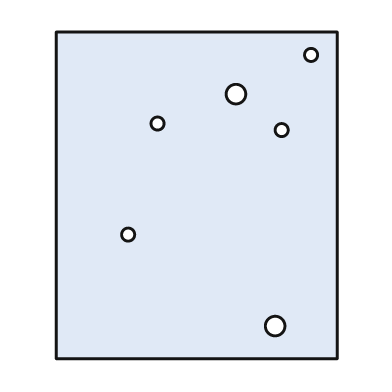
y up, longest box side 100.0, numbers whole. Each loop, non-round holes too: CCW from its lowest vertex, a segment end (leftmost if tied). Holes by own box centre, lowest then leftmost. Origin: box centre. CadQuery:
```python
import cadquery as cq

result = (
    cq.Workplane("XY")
    .moveTo(-43.0, -50.0)
    .lineTo(43.0, -50.0)
    .lineTo(43.0, 50.0)
    .lineTo(-43.0, 50.0)
    .close()
    .moveTo(24.0, -40.0)
    .circle(3.0)
    .moveTo(-21.0, -12.0)
    .circle(2.0)
    .moveTo(26.0, 20.0)
    .circle(2.0)
    .moveTo(-12.0, 22.0)
    .circle(2.0)
    .moveTo(12.0, 31.0)
    .circle(3.0)
    .moveTo(35.0, 43.0)
    .circle(2.0)
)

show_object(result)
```